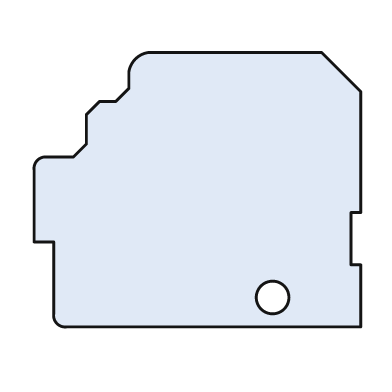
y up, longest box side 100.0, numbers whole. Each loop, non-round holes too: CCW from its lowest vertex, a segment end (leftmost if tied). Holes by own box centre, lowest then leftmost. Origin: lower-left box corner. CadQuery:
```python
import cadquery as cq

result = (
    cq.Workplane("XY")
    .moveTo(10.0, 0.0)
    .lineTo(100.0, 0.0)
    .lineTo(100.0, 19.0)
    .lineTo(97.0, 19.0)
    .lineTo(97.0, 35.0)
    .lineTo(100.0, 35.0)
    .lineTo(100.0, 72.0)
    .lineTo(88.0, 84.0)
    .lineTo(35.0, 84.0)
    .threePointArc((31.0, 82.0), (29.0, 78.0))
    .lineTo(29.0, 73.0)
    .lineTo(25.0, 69.0)
    .lineTo(20.0, 69.0)
    .lineTo(16.0, 65.0)
    .lineTo(16.0, 56.0)
    .lineTo(12.0, 52.0)
    .lineTo(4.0, 52.0)
    .threePointArc((1.0, 51.0), (0.0, 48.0))
    .lineTo(0.0, 26.0)
    .lineTo(6.0, 26.0)
    .lineTo(6.0, 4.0)
    .threePointArc((7.0, 1.0), (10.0, 0.0))
    .close()
    .moveTo(73.0, 9.0)
    .circle(5.0)
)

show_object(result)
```